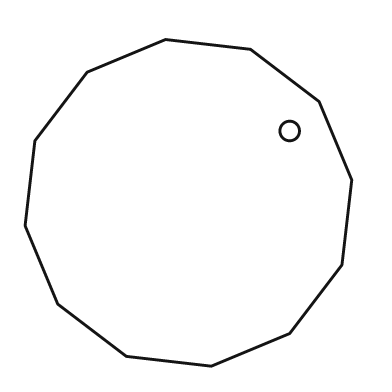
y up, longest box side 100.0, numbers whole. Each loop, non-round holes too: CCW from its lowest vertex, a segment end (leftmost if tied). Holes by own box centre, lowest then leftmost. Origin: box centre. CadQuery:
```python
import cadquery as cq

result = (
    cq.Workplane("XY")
    .moveTo(7.0, -50.0)
    .lineTo(31.0, -40.0)
    .lineTo(47.0, -19.0)
    .lineTo(50.0, 7.0)
    .lineTo(40.0, 31.0)
    .lineTo(19.0, 47.0)
    .lineTo(-7.0, 50.0)
    .lineTo(-31.0, 40.0)
    .lineTo(-47.0, 19.0)
    .lineTo(-50.0, -7.0)
    .lineTo(-40.0, -31.0)
    .lineTo(-19.0, -47.0)
    .close()
    .moveTo(31.0, 22.0)
    .circle(3.0)
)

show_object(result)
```